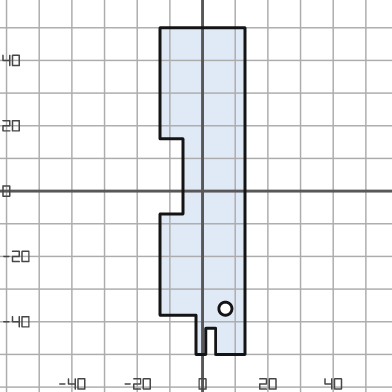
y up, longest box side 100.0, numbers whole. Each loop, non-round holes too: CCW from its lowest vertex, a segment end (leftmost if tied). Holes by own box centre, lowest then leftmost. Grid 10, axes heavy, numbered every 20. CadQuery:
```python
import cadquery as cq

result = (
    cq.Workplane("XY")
    .moveTo(-2.0, -50.0)
    .lineTo(1.0, -50.0)
    .lineTo(1.0, -42.0)
    .lineTo(4.0, -42.0)
    .lineTo(4.0, -50.0)
    .lineTo(13.0, -50.0)
    .lineTo(13.0, 50.0)
    .lineTo(-13.0, 50.0)
    .lineTo(-13.0, 16.0)
    .lineTo(-6.0, 16.0)
    .lineTo(-6.0, -7.0)
    .lineTo(-13.0, -7.0)
    .lineTo(-13.0, -38.0)
    .lineTo(-2.0, -38.0)
    .close()
    .moveTo(7.0, -36.0)
    .circle(2.0)
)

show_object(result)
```